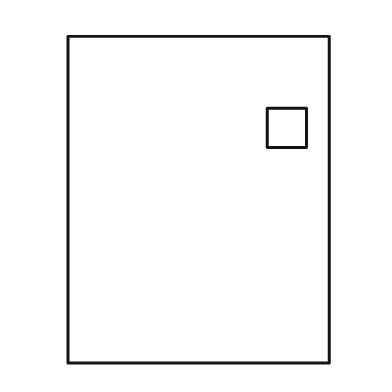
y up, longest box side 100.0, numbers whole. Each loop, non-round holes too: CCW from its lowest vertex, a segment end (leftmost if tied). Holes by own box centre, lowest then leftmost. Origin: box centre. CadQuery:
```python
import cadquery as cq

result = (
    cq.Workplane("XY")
    .moveTo(-40.0, -50.0)
    .lineTo(40.0, -50.0)
    .lineTo(40.0, 50.0)
    .lineTo(-40.0, 50.0)
    .close()
    .moveTo(21.0, 16.0)
    .lineTo(33.0, 16.0)
    .lineTo(33.0, 28.0)
    .lineTo(21.0, 28.0)
    .close()
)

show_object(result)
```